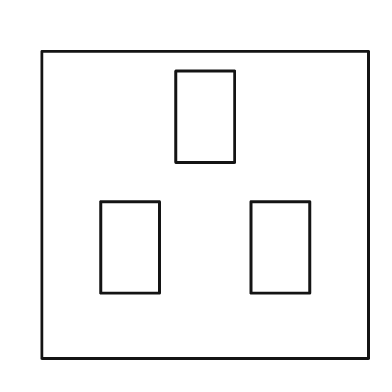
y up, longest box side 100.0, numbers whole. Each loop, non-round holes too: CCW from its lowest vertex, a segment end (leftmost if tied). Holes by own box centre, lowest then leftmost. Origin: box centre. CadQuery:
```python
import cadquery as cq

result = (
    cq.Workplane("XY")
    .moveTo(-50.0, -47.0)
    .lineTo(50.0, -47.0)
    .lineTo(50.0, 47.0)
    .lineTo(-50.0, 47.0)
    .close()
    .moveTo(-32.0, -27.0)
    .lineTo(-14.0, -27.0)
    .lineTo(-14.0, 1.0)
    .lineTo(-32.0, 1.0)
    .close()
    .moveTo(14.0, -27.0)
    .lineTo(32.0, -27.0)
    .lineTo(32.0, 1.0)
    .lineTo(14.0, 1.0)
    .close()
    .moveTo(-9.0, 13.0)
    .lineTo(9.0, 13.0)
    .lineTo(9.0, 41.0)
    .lineTo(-9.0, 41.0)
    .close()
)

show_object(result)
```